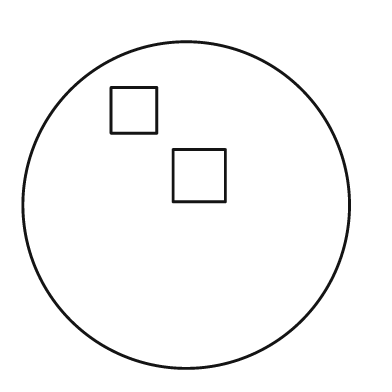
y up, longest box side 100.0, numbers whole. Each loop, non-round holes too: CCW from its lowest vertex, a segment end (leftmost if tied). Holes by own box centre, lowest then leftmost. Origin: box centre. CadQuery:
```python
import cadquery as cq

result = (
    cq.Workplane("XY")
    .moveTo(0.0, 0.0)
    .circle(50.0)
    .moveTo(-4.0, 1.0)
    .lineTo(12.0, 1.0)
    .lineTo(12.0, 17.0)
    .lineTo(-4.0, 17.0)
    .close()
    .moveTo(-23.0, 22.0)
    .lineTo(-9.0, 22.0)
    .lineTo(-9.0, 36.0)
    .lineTo(-23.0, 36.0)
    .close()
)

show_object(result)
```